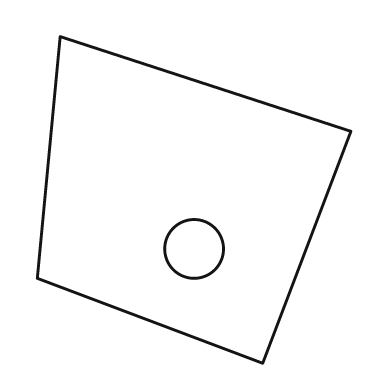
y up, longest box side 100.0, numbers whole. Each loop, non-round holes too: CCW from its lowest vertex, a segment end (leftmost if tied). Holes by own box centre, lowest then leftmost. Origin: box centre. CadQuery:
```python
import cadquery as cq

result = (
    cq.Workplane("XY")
    .moveTo(21.0, -50.0)
    .lineTo(48.0, 21.0)
    .lineTo(-41.0, 50.0)
    .lineTo(-48.0, -24.0)
    .close()
    .moveTo(0.0, -15.0)
    .circle(9.0)
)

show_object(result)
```